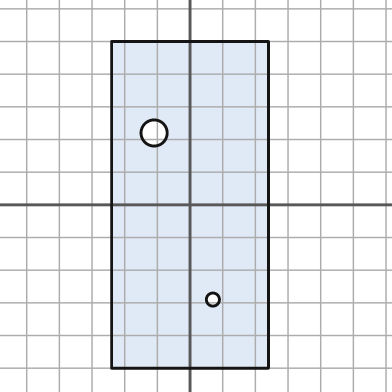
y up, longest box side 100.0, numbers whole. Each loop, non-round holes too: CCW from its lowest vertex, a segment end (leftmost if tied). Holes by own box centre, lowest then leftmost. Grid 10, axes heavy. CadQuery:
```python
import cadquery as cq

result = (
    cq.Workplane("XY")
    .moveTo(-24.0, -50.0)
    .lineTo(24.0, -50.0)
    .lineTo(24.0, 50.0)
    .lineTo(-24.0, 50.0)
    .close()
    .moveTo(7.0, -29.0)
    .circle(2.0)
    .moveTo(-11.0, 22.0)
    .circle(4.0)
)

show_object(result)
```